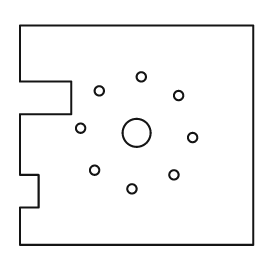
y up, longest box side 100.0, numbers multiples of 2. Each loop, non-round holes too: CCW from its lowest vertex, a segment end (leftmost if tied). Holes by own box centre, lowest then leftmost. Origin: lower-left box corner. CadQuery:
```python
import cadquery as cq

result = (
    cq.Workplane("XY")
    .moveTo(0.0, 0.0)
    .lineTo(100.0, 0.0)
    .lineTo(100.0, 94.0)
    .lineTo(0.0, 94.0)
    .lineTo(0.0, 70.0)
    .lineTo(22.0, 70.0)
    .lineTo(22.0, 56.0)
    .lineTo(0.0, 56.0)
    .lineTo(0.0, 30.0)
    .lineTo(8.0, 30.0)
    .lineTo(8.0, 16.0)
    .lineTo(0.0, 16.0)
    .close()
    .moveTo(48.0, 24.0)
    .circle(2.0)
    .moveTo(66.0, 30.0)
    .circle(2.0)
    .moveTo(32.0, 32.0)
    .circle(2.0)
    .moveTo(74.0, 46.0)
    .circle(2.0)
    .moveTo(50.0, 48.0)
    .circle(6.0)
    .moveTo(26.0, 50.0)
    .circle(2.0)
    .moveTo(68.0, 64.0)
    .circle(2.0)
    .moveTo(34.0, 66.0)
    .circle(2.0)
    .moveTo(52.0, 72.0)
    .circle(2.0)
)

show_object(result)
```